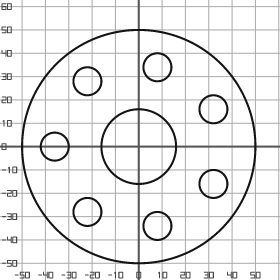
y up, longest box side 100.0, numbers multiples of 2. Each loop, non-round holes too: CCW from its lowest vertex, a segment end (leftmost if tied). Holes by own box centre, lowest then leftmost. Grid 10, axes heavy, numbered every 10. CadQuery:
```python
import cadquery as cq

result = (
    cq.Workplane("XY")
    .moveTo(0.0, 0.0)
    .circle(50.0)
    .moveTo(8.0, -34.0)
    .circle(6.0)
    .moveTo(-22.0, -28.0)
    .circle(6.0)
    .moveTo(32.0, -16.0)
    .circle(6.0)
    .moveTo(-36.0, 0.0)
    .circle(6.0)
    .moveTo(0.0, 0.0)
    .circle(16.0)
    .moveTo(32.0, 16.0)
    .circle(6.0)
    .moveTo(-22.0, 28.0)
    .circle(6.0)
    .moveTo(8.0, 34.0)
    .circle(6.0)
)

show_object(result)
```